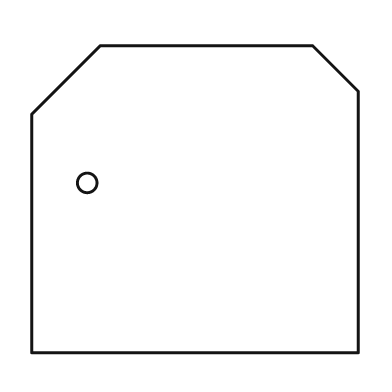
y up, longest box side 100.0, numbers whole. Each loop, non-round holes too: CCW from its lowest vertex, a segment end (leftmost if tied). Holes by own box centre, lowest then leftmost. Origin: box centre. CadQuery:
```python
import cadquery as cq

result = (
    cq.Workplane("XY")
    .moveTo(-50.0, -47.0)
    .lineTo(50.0, -47.0)
    .lineTo(50.0, 33.0)
    .lineTo(36.0, 47.0)
    .lineTo(-29.0, 47.0)
    .lineTo(-50.0, 26.0)
    .close()
    .moveTo(-33.0, 5.0)
    .circle(3.0)
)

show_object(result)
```